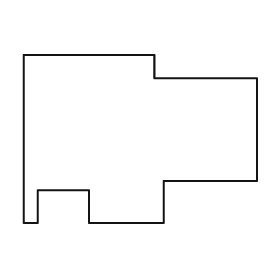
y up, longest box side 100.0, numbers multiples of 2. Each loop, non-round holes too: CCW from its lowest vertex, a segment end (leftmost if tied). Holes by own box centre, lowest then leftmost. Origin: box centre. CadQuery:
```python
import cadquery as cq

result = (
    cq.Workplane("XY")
    .moveTo(-50.0, -36.0)
    .lineTo(-44.0, -36.0)
    .lineTo(-44.0, -22.0)
    .lineTo(-22.0, -22.0)
    .lineTo(-22.0, -36.0)
    .lineTo(10.0, -36.0)
    .lineTo(10.0, -18.0)
    .lineTo(50.0, -18.0)
    .lineTo(50.0, 26.0)
    .lineTo(6.0, 26.0)
    .lineTo(6.0, 36.0)
    .lineTo(-50.0, 36.0)
    .close()
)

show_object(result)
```